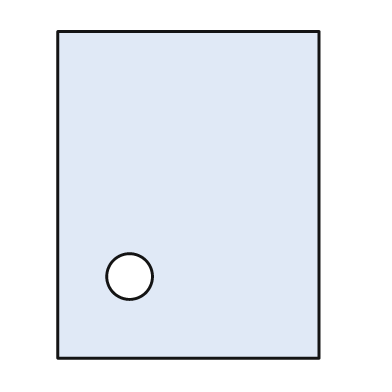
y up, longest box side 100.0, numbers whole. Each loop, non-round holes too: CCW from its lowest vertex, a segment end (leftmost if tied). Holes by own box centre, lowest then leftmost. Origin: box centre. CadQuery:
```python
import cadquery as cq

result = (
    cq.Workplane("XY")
    .moveTo(-40.0, -50.0)
    .lineTo(40.0, -50.0)
    .lineTo(40.0, 50.0)
    .lineTo(-40.0, 50.0)
    .close()
    .moveTo(-18.0, -25.0)
    .circle(7.0)
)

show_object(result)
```